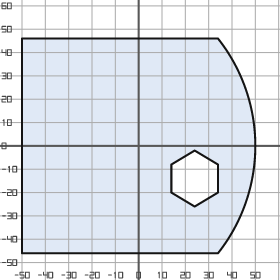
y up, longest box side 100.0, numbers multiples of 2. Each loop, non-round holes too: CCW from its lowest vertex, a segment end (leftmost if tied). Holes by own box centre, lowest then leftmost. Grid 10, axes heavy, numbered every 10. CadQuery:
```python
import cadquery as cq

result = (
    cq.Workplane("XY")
    .moveTo(-50.0, -46.0)
    .lineTo(34.0, -46.0)
    .threePointArc((50.0, 0.0), (34.0, 46.0))
    .lineTo(-50.0, 46.0)
    .close()
    .moveTo(24.0, -26.0)
    .lineTo(34.0, -20.0)
    .lineTo(34.0, -8.0)
    .lineTo(24.0, -2.0)
    .lineTo(14.0, -8.0)
    .lineTo(14.0, -20.0)
    .close()
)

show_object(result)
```